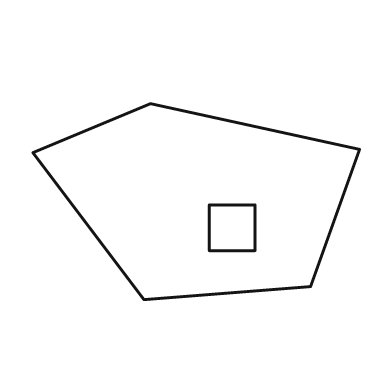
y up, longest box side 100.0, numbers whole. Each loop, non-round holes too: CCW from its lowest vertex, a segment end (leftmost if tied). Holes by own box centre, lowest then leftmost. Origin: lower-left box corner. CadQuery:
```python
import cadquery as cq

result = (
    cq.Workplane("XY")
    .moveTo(34.0, 0.0)
    .lineTo(85.0, 4.0)
    .lineTo(100.0, 46.0)
    .lineTo(36.0, 60.0)
    .lineTo(0.0, 45.0)
    .close()
    .moveTo(54.0, 15.0)
    .lineTo(68.0, 15.0)
    .lineTo(68.0, 29.0)
    .lineTo(54.0, 29.0)
    .close()
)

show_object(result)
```